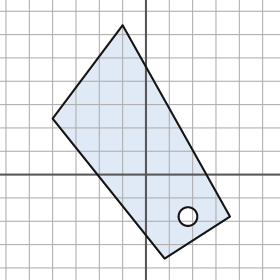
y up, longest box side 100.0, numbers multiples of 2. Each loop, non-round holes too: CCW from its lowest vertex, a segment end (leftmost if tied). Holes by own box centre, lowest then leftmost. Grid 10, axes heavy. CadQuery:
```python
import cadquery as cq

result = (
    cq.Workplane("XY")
    .moveTo(8.0, -36.0)
    .lineTo(36.0, -18.0)
    .lineTo(-10.0, 64.0)
    .lineTo(-40.0, 24.0)
    .close()
    .moveTo(18.0, -18.0)
    .circle(4.0)
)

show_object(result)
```